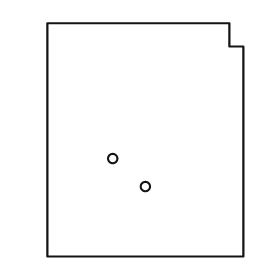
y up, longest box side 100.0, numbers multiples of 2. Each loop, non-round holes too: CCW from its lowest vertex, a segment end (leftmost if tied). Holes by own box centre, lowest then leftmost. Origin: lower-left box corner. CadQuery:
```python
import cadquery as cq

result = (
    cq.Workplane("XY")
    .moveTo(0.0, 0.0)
    .lineTo(84.0, 0.0)
    .lineTo(84.0, 90.0)
    .lineTo(78.0, 90.0)
    .lineTo(78.0, 100.0)
    .lineTo(0.0, 100.0)
    .close()
    .moveTo(42.0, 30.0)
    .circle(2.0)
    .moveTo(28.0, 42.0)
    .circle(2.0)
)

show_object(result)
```